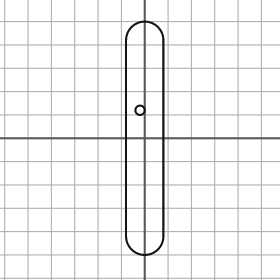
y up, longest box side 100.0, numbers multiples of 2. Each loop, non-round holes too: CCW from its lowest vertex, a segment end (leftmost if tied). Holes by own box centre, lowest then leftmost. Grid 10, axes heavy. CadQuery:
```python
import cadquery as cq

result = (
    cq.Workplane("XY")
    .moveTo(-8.0, -42.0)
    .threePointArc((0.0, -50.0), (8.0, -42.0))
    .lineTo(8.0, 42.0)
    .threePointArc((0.0, 50.0), (-8.0, 42.0))
    .close()
    .moveTo(-2.0, 12.0)
    .circle(2.0)
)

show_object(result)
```